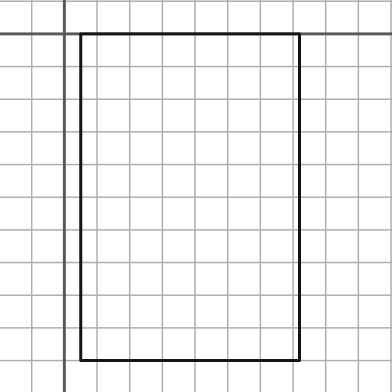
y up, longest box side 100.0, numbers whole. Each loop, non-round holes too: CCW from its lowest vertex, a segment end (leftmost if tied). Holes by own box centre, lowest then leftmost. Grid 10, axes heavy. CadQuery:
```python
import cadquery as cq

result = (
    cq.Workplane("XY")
    .moveTo(5.0, -100.0)
    .lineTo(72.0, -100.0)
    .lineTo(72.0, 0.0)
    .lineTo(5.0, 0.0)
    .close()
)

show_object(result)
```